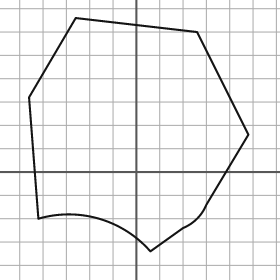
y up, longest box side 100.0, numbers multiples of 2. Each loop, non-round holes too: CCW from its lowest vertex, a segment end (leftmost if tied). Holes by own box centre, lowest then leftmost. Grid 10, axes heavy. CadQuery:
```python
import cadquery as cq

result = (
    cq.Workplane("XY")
    .moveTo(6.0, -34.0)
    .lineTo(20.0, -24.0)
    .threePointArc((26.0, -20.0), (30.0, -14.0))
    .lineTo(48.0, 16.0)
    .lineTo(26.0, 60.0)
    .lineTo(-26.0, 66.0)
    .lineTo(-46.0, 32.0)
    .lineTo(-42.0, -20.0)
    .threePointArc((-16.0, -20.0), (6.0, -34.0))
    .close()
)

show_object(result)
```